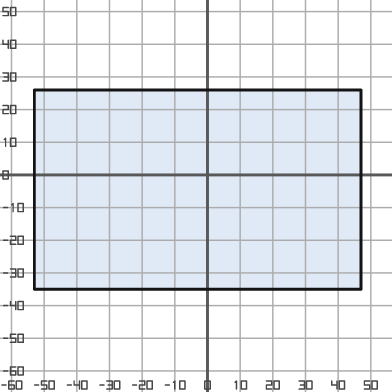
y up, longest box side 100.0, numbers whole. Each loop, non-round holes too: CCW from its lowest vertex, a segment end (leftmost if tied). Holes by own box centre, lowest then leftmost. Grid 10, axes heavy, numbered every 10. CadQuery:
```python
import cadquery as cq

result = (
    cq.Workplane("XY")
    .moveTo(-53.0, -35.0)
    .lineTo(47.0, -35.0)
    .lineTo(47.0, 26.0)
    .lineTo(-53.0, 26.0)
    .close()
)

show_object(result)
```